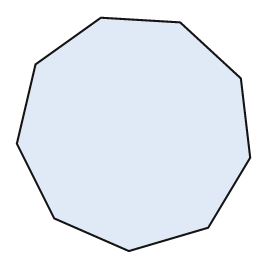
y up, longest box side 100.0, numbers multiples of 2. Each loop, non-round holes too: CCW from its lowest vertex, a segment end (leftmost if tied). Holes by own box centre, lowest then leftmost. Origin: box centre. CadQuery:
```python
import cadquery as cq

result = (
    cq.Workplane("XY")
    .moveTo(-2.0, -50.0)
    .lineTo(32.0, -40.0)
    .lineTo(50.0, -10.0)
    .lineTo(46.0, 24.0)
    .lineTo(20.0, 48.0)
    .lineTo(-14.0, 50.0)
    .lineTo(-42.0, 30.0)
    .lineTo(-50.0, -4.0)
    .lineTo(-34.0, -36.0)
    .close()
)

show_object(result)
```